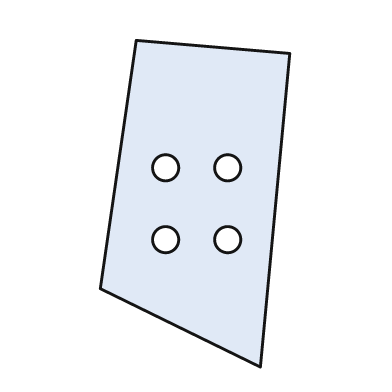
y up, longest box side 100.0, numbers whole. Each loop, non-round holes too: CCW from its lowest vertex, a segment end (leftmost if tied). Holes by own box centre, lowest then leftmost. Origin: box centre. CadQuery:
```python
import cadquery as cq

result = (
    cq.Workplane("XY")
    .moveTo(20.0, -50.0)
    .lineTo(29.0, 46.0)
    .lineTo(-18.0, 50.0)
    .lineTo(-29.0, -26.0)
    .close()
    .moveTo(-9.0, -11.0)
    .circle(4.0)
    .moveTo(10.0, -11.0)
    .circle(4.0)
    .moveTo(-9.0, 11.0)
    .circle(4.0)
    .moveTo(10.0, 11.0)
    .circle(4.0)
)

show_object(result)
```